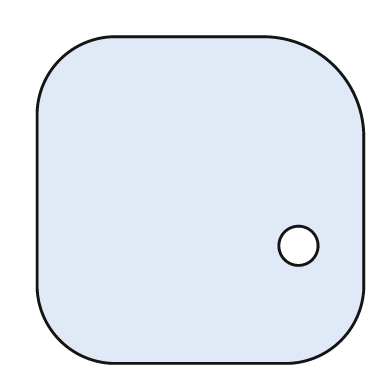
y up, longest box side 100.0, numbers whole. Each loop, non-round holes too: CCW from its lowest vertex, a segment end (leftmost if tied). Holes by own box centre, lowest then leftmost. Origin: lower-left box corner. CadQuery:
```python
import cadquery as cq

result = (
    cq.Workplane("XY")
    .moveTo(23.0, 0.0)
    .lineTo(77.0, 0.0)
    .threePointArc((93.0, 7.0), (100.0, 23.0))
    .lineTo(100.0, 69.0)
    .threePointArc((91.0, 91.0), (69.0, 100.0))
    .lineTo(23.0, 100.0)
    .threePointArc((7.0, 93.0), (0.0, 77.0))
    .lineTo(0.0, 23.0)
    .threePointArc((7.0, 7.0), (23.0, 0.0))
    .close()
    .moveTo(80.0, 36.0)
    .circle(6.0)
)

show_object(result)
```